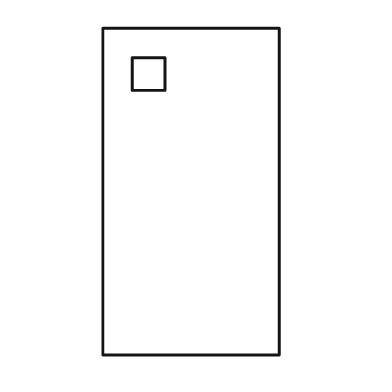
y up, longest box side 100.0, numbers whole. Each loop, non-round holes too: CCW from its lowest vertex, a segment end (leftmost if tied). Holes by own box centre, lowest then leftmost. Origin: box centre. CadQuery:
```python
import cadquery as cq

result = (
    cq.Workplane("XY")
    .moveTo(-27.0, -50.0)
    .lineTo(27.0, -50.0)
    .lineTo(27.0, 50.0)
    .lineTo(-27.0, 50.0)
    .close()
    .moveTo(-18.0, 31.0)
    .lineTo(-8.0, 31.0)
    .lineTo(-8.0, 41.0)
    .lineTo(-18.0, 41.0)
    .close()
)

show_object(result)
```